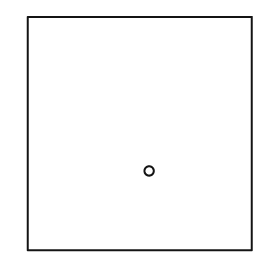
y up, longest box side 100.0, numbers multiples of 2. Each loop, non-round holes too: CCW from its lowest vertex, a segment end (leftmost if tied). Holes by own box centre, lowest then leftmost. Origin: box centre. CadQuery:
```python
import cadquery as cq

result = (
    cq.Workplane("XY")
    .moveTo(-48.0, -50.0)
    .lineTo(48.0, -50.0)
    .lineTo(48.0, 50.0)
    .lineTo(-48.0, 50.0)
    .close()
    .moveTo(4.0, -16.0)
    .circle(2.0)
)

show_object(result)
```